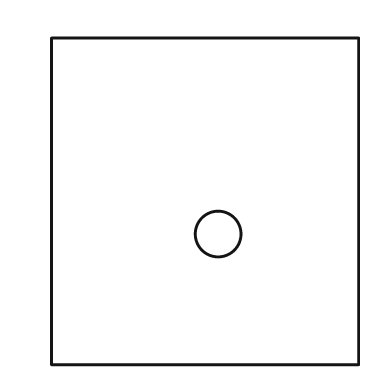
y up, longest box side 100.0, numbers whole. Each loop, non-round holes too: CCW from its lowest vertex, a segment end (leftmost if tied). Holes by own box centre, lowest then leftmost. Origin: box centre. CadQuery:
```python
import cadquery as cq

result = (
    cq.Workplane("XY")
    .moveTo(-47.0, -50.0)
    .lineTo(47.0, -50.0)
    .lineTo(47.0, 50.0)
    .lineTo(-47.0, 50.0)
    .close()
    .moveTo(4.0, -10.0)
    .circle(7.0)
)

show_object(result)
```